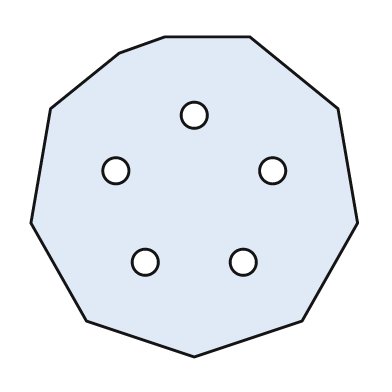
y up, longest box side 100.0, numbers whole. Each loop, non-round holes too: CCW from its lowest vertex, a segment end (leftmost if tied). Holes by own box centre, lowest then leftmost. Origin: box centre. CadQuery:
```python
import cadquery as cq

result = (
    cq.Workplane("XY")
    .moveTo(0.0, -49.0)
    .lineTo(33.0, -38.0)
    .lineTo(50.0, -8.0)
    .lineTo(44.0, 27.0)
    .lineTo(17.0, 49.0)
    .lineTo(-9.0, 49.0)
    .lineTo(-23.0, 44.0)
    .lineTo(-44.0, 27.0)
    .lineTo(-50.0, -8.0)
    .lineTo(-33.0, -38.0)
    .close()
    .moveTo(-15.0, -20.0)
    .circle(4.0)
    .moveTo(15.0, -20.0)
    .circle(4.0)
    .moveTo(-24.0, 8.0)
    .circle(4.0)
    .moveTo(24.0, 8.0)
    .circle(4.0)
    .moveTo(0.0, 25.0)
    .circle(4.0)
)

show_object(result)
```